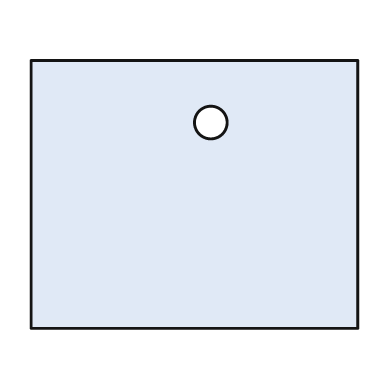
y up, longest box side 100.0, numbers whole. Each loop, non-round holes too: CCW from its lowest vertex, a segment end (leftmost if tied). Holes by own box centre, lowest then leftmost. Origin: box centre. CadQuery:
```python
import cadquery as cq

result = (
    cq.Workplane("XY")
    .moveTo(-50.0, -41.0)
    .lineTo(50.0, -41.0)
    .lineTo(50.0, 41.0)
    .lineTo(-50.0, 41.0)
    .close()
    .moveTo(5.0, 22.0)
    .circle(5.0)
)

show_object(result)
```